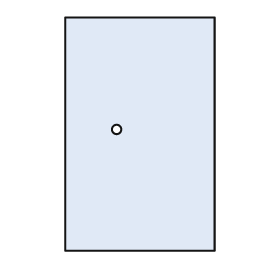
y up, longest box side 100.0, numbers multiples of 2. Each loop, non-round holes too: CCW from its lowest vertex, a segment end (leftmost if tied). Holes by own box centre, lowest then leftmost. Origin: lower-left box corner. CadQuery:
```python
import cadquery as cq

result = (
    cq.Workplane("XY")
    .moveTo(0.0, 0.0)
    .lineTo(64.0, 0.0)
    .lineTo(64.0, 100.0)
    .lineTo(0.0, 100.0)
    .close()
    .moveTo(22.0, 52.0)
    .circle(2.0)
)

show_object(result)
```